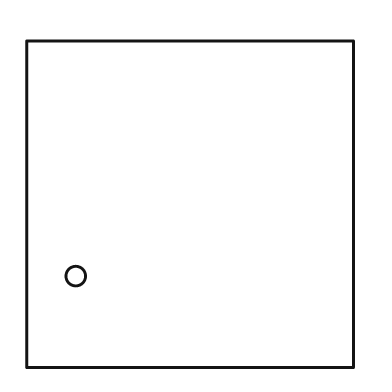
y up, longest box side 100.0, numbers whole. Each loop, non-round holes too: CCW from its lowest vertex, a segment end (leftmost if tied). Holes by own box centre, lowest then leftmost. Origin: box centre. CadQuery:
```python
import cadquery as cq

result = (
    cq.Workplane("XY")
    .moveTo(-50.0, -50.0)
    .lineTo(50.0, -50.0)
    .lineTo(50.0, 50.0)
    .lineTo(-50.0, 50.0)
    .close()
    .moveTo(-35.0, -22.0)
    .circle(3.0)
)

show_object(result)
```